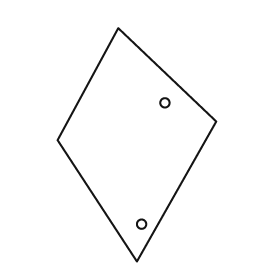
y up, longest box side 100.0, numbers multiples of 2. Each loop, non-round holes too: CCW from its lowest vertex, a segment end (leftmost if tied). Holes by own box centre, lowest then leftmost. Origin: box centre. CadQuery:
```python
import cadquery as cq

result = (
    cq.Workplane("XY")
    .moveTo(0.0, -50.0)
    .lineTo(34.0, 10.0)
    .lineTo(-8.0, 50.0)
    .lineTo(-34.0, 2.0)
    .close()
    .moveTo(2.0, -34.0)
    .circle(2.0)
    .moveTo(12.0, 18.0)
    .circle(2.0)
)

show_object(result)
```